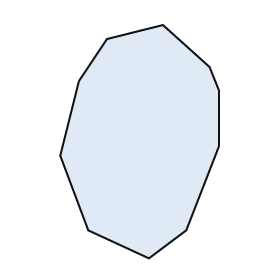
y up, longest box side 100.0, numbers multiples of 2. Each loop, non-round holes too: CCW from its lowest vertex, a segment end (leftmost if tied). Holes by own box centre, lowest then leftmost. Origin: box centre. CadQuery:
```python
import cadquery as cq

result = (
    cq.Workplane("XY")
    .moveTo(4.0, -50.0)
    .lineTo(20.0, -38.0)
    .lineTo(34.0, -2.0)
    .lineTo(34.0, 22.0)
    .lineTo(30.0, 32.0)
    .lineTo(10.0, 50.0)
    .lineTo(-14.0, 44.0)
    .lineTo(-26.0, 26.0)
    .lineTo(-34.0, -6.0)
    .lineTo(-22.0, -38.0)
    .close()
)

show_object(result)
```